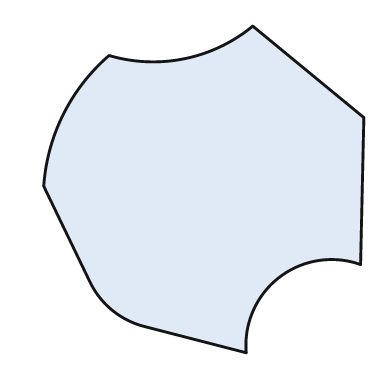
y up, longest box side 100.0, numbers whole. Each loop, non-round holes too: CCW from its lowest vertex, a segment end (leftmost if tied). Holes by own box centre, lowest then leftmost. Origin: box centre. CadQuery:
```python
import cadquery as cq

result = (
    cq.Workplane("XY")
    .moveTo(13.0, -50.0)
    .threePointArc((23.0, -27.0), (48.0, -23.0))
    .lineTo(49.0, 22.0)
    .lineTo(15.0, 50.0)
    .threePointArc((-6.0, 40.0), (-29.0, 41.0))
    .threePointArc((-43.0, 23.0), (-49.0, 1.0))
    .lineTo(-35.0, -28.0)
    .threePointArc((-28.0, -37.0), (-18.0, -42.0))
    .close()
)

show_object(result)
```